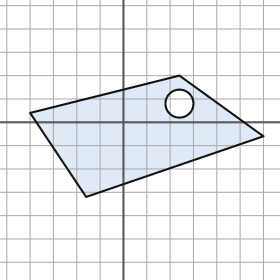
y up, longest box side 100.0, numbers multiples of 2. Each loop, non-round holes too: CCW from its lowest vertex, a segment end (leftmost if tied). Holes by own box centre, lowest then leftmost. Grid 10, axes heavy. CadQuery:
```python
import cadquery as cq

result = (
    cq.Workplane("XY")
    .moveTo(-16.0, -32.0)
    .lineTo(60.0, -6.0)
    .lineTo(24.0, 20.0)
    .lineTo(-40.0, 4.0)
    .close()
    .moveTo(24.0, 8.0)
    .circle(6.0)
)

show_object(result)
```